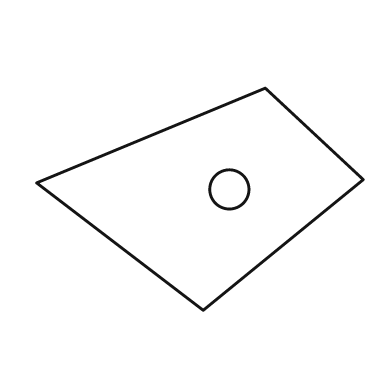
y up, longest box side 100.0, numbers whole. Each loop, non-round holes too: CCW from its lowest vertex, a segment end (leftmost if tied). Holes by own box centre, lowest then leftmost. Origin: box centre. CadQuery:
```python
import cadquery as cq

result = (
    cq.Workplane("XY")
    .moveTo(1.0, -34.0)
    .lineTo(50.0, 6.0)
    .lineTo(20.0, 34.0)
    .lineTo(-50.0, 5.0)
    .close()
    .moveTo(9.0, 3.0)
    .circle(6.0)
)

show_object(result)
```